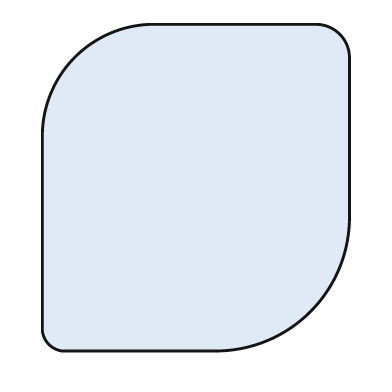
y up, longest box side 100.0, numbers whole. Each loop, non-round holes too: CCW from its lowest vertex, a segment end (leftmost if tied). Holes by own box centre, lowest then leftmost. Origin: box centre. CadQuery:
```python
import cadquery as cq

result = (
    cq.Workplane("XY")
    .moveTo(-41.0, -50.0)
    .lineTo(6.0, -50.0)
    .threePointArc((35.0, -38.0), (47.0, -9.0))
    .lineTo(47.0, 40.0)
    .threePointArc((44.0, 47.0), (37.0, 50.0))
    .lineTo(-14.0, 50.0)
    .threePointArc((-37.0, 40.0), (-47.0, 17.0))
    .lineTo(-47.0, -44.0)
    .threePointArc((-45.0, -48.0), (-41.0, -50.0))
    .close()
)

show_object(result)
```